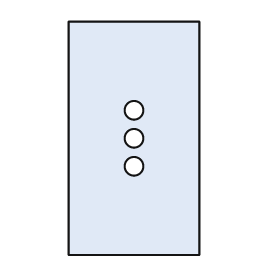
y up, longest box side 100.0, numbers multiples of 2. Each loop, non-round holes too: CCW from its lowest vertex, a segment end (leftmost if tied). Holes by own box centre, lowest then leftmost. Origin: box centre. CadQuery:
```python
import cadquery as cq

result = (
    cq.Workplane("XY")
    .moveTo(-28.0, -50.0)
    .lineTo(28.0, -50.0)
    .lineTo(28.0, 50.0)
    .lineTo(-28.0, 50.0)
    .close()
    .moveTo(0.0, -12.0)
    .circle(4.0)
    .moveTo(0.0, 0.0)
    .circle(4.0)
    .moveTo(0.0, 12.0)
    .circle(4.0)
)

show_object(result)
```